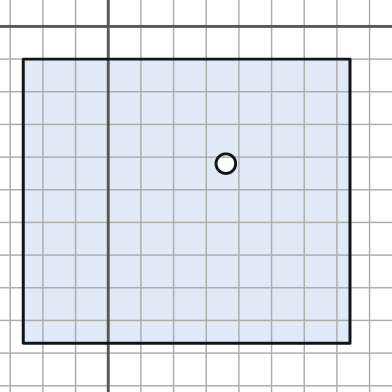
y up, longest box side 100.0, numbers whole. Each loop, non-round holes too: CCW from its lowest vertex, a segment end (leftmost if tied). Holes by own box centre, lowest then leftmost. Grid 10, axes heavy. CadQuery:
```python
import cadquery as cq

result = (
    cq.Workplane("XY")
    .moveTo(-26.0, -97.0)
    .lineTo(74.0, -97.0)
    .lineTo(74.0, -10.0)
    .lineTo(-26.0, -10.0)
    .close()
    .moveTo(36.0, -42.0)
    .circle(3.0)
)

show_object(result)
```